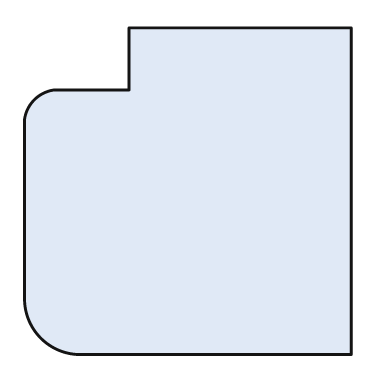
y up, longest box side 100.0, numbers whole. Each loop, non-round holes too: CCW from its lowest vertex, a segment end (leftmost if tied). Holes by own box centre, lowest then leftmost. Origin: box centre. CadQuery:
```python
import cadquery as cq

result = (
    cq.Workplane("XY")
    .moveTo(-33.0, -50.0)
    .lineTo(50.0, -50.0)
    .lineTo(50.0, 50.0)
    .lineTo(-18.0, 50.0)
    .lineTo(-18.0, 31.0)
    .lineTo(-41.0, 31.0)
    .threePointArc((-47.0, 28.0), (-50.0, 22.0))
    .lineTo(-50.0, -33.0)
    .threePointArc((-45.0, -45.0), (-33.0, -50.0))
    .close()
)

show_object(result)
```